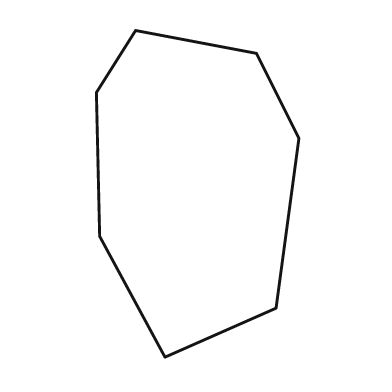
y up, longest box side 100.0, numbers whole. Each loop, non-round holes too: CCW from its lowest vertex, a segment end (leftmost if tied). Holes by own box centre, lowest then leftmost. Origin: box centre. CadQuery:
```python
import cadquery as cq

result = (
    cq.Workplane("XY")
    .moveTo(-10.0, -50.0)
    .lineTo(24.0, -35.0)
    .lineTo(31.0, 17.0)
    .lineTo(18.0, 43.0)
    .lineTo(-19.0, 50.0)
    .lineTo(-31.0, 31.0)
    .lineTo(-30.0, -13.0)
    .close()
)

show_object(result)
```